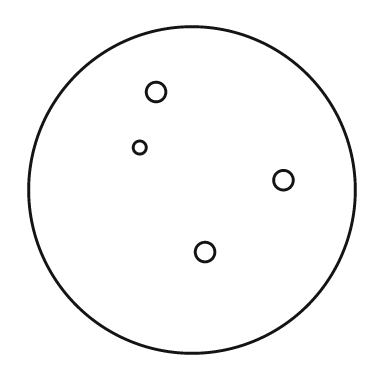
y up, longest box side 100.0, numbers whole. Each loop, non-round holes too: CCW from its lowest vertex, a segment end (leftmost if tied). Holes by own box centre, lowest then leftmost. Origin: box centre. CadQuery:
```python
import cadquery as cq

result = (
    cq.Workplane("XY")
    .moveTo(0.0, 0.0)
    .circle(50.0)
    .moveTo(4.0, -19.0)
    .circle(3.0)
    .moveTo(28.0, 3.0)
    .circle(3.0)
    .moveTo(-16.0, 13.0)
    .circle(2.0)
    .moveTo(-11.0, 30.0)
    .circle(3.0)
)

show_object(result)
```